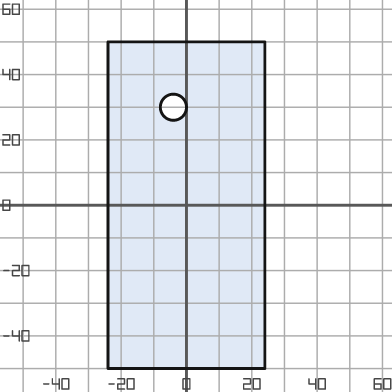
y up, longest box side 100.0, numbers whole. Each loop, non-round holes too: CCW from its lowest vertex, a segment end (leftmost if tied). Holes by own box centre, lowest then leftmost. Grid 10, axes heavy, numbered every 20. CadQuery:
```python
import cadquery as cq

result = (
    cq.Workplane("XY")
    .moveTo(-24.0, -50.0)
    .lineTo(24.0, -50.0)
    .lineTo(24.0, 50.0)
    .lineTo(-24.0, 50.0)
    .close()
    .moveTo(-4.0, 30.0)
    .circle(4.0)
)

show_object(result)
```